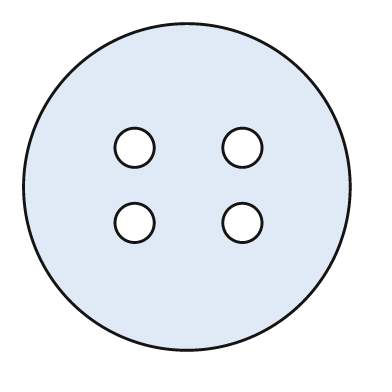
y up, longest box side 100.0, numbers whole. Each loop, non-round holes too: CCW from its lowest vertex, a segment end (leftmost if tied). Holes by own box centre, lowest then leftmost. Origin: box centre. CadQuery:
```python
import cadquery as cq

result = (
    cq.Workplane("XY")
    .moveTo(0.0, 0.0)
    .circle(50.0)
    .moveTo(-16.0, -11.0)
    .circle(6.0)
    .moveTo(17.0, -11.0)
    .circle(6.0)
    .moveTo(-16.0, 12.0)
    .circle(6.0)
    .moveTo(17.0, 12.0)
    .circle(6.0)
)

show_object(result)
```